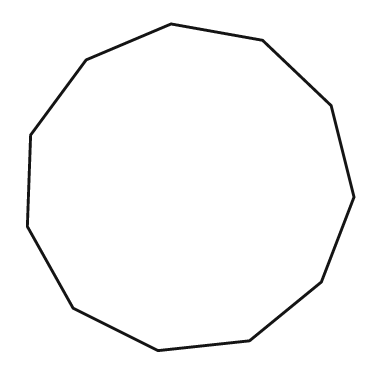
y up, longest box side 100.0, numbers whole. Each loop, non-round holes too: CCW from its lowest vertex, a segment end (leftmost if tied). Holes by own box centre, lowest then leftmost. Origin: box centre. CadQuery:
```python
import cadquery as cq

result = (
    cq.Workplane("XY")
    .moveTo(-10.0, -50.0)
    .lineTo(18.0, -47.0)
    .lineTo(40.0, -29.0)
    .lineTo(50.0, -3.0)
    .lineTo(43.0, 25.0)
    .lineTo(22.0, 45.0)
    .lineTo(-6.0, 50.0)
    .lineTo(-32.0, 39.0)
    .lineTo(-49.0, 16.0)
    .lineTo(-50.0, -12.0)
    .lineTo(-36.0, -37.0)
    .close()
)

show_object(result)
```